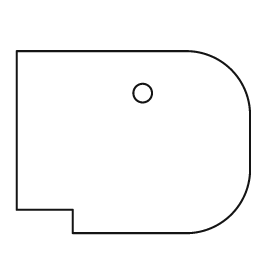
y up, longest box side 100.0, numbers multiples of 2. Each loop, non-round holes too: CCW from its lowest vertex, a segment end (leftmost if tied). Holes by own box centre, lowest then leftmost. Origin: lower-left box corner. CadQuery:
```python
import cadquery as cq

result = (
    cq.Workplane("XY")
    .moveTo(24.0, 0.0)
    .lineTo(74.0, 0.0)
    .threePointArc((92.0, 8.0), (100.0, 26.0))
    .lineTo(100.0, 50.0)
    .threePointArc((92.0, 70.0), (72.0, 78.0))
    .lineTo(0.0, 78.0)
    .lineTo(0.0, 10.0)
    .lineTo(24.0, 10.0)
    .close()
    .moveTo(54.0, 60.0)
    .circle(4.0)
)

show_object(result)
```